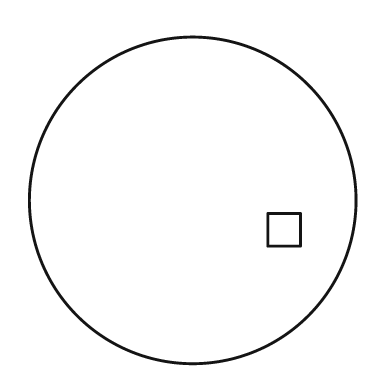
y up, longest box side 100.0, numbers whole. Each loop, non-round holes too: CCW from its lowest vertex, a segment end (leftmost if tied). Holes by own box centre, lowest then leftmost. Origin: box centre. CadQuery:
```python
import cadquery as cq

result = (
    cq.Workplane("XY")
    .moveTo(0.0, 0.0)
    .circle(50.0)
    .moveTo(23.0, -14.0)
    .lineTo(33.0, -14.0)
    .lineTo(33.0, -4.0)
    .lineTo(23.0, -4.0)
    .close()
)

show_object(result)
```